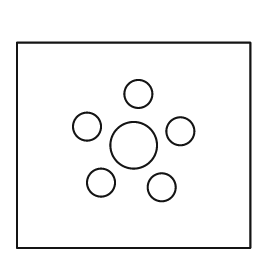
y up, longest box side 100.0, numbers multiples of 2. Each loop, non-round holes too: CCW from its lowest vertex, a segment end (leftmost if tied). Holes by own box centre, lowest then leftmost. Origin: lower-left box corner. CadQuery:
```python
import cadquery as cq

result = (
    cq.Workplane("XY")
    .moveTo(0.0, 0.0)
    .lineTo(100.0, 0.0)
    .lineTo(100.0, 88.0)
    .lineTo(0.0, 88.0)
    .close()
    .moveTo(62.0, 26.0)
    .circle(6.0)
    .moveTo(36.0, 28.0)
    .circle(6.0)
    .moveTo(50.0, 44.0)
    .circle(10.0)
    .moveTo(70.0, 50.0)
    .circle(6.0)
    .moveTo(30.0, 52.0)
    .circle(6.0)
    .moveTo(52.0, 66.0)
    .circle(6.0)
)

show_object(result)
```